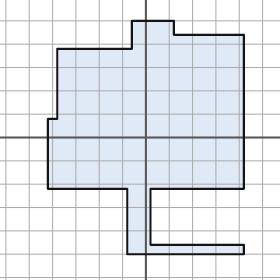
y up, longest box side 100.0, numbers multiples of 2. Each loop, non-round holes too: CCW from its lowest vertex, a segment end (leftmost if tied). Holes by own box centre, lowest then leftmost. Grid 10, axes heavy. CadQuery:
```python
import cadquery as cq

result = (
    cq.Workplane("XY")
    .moveTo(-8.0, -50.0)
    .lineTo(42.0, -50.0)
    .lineTo(42.0, -46.0)
    .lineTo(2.0, -46.0)
    .lineTo(2.0, -22.0)
    .lineTo(42.0, -22.0)
    .lineTo(42.0, 44.0)
    .lineTo(12.0, 44.0)
    .lineTo(12.0, 50.0)
    .lineTo(-6.0, 50.0)
    .lineTo(-6.0, 38.0)
    .lineTo(-38.0, 38.0)
    .lineTo(-38.0, 8.0)
    .lineTo(-42.0, 8.0)
    .lineTo(-42.0, -22.0)
    .lineTo(-8.0, -22.0)
    .close()
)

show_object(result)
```